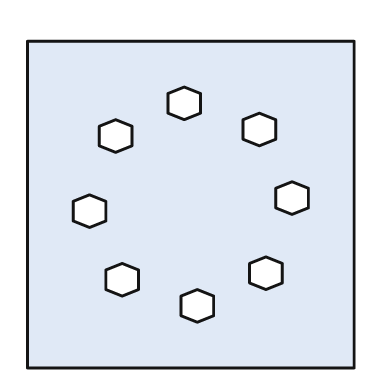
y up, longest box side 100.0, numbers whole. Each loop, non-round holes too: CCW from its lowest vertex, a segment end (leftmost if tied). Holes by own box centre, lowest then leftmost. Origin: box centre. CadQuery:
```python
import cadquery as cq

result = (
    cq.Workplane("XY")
    .moveTo(-50.0, -50.0)
    .lineTo(50.0, -50.0)
    .lineTo(50.0, 50.0)
    .lineTo(-50.0, 50.0)
    .close()
    .moveTo(2.0, -36.0)
    .lineTo(7.0, -34.0)
    .lineTo(7.0, -28.0)
    .lineTo(2.0, -26.0)
    .lineTo(-3.0, -28.0)
    .lineTo(-3.0, -34.0)
    .close()
    .moveTo(-21.0, -28.0)
    .lineTo(-16.0, -26.0)
    .lineTo(-16.0, -20.0)
    .lineTo(-21.0, -18.0)
    .lineTo(-26.0, -20.0)
    .lineTo(-26.0, -26.0)
    .close()
    .moveTo(23.0, -26.0)
    .lineTo(28.0, -24.0)
    .lineTo(28.0, -18.0)
    .lineTo(23.0, -16.0)
    .lineTo(18.0, -18.0)
    .lineTo(18.0, -24.0)
    .close()
    .moveTo(-31.0, -7.0)
    .lineTo(-26.0, -5.0)
    .lineTo(-26.0, 1.0)
    .lineTo(-31.0, 3.0)
    .lineTo(-36.0, 1.0)
    .lineTo(-36.0, -5.0)
    .close()
    .moveTo(31.0, -3.0)
    .lineTo(36.0, -1.0)
    .lineTo(36.0, 5.0)
    .lineTo(31.0, 7.0)
    .lineTo(26.0, 5.0)
    .lineTo(26.0, -1.0)
    .close()
    .moveTo(-23.0, 16.0)
    .lineTo(-18.0, 18.0)
    .lineTo(-18.0, 24.0)
    .lineTo(-23.0, 26.0)
    .lineTo(-28.0, 24.0)
    .lineTo(-28.0, 18.0)
    .close()
    .moveTo(21.0, 18.0)
    .lineTo(26.0, 20.0)
    .lineTo(26.0, 26.0)
    .lineTo(21.0, 28.0)
    .lineTo(16.0, 26.0)
    .lineTo(16.0, 20.0)
    .close()
    .moveTo(-2.0, 26.0)
    .lineTo(3.0, 28.0)
    .lineTo(3.0, 34.0)
    .lineTo(-2.0, 36.0)
    .lineTo(-7.0, 34.0)
    .lineTo(-7.0, 28.0)
    .close()
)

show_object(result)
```